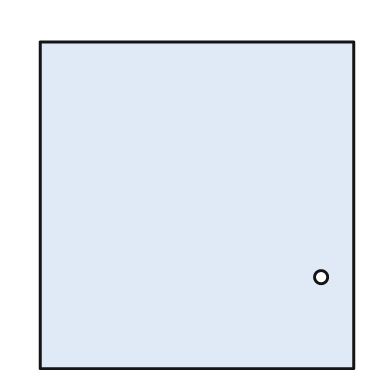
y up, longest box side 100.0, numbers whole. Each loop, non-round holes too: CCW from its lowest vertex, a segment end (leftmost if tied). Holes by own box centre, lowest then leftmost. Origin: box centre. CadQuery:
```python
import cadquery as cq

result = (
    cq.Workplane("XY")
    .moveTo(-48.0, -50.0)
    .lineTo(48.0, -50.0)
    .lineTo(48.0, 50.0)
    .lineTo(-48.0, 50.0)
    .close()
    .moveTo(38.0, -22.0)
    .circle(2.0)
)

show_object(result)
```